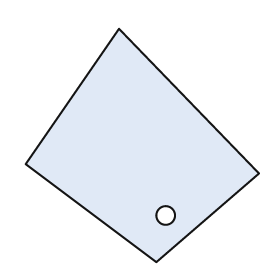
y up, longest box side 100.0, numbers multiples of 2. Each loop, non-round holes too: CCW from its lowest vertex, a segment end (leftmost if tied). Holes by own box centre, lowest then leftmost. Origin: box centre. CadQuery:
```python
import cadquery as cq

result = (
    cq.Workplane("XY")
    .moveTo(6.0, -50.0)
    .lineTo(50.0, -12.0)
    .lineTo(-10.0, 50.0)
    .lineTo(-50.0, -8.0)
    .close()
    .moveTo(10.0, -30.0)
    .circle(4.0)
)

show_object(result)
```